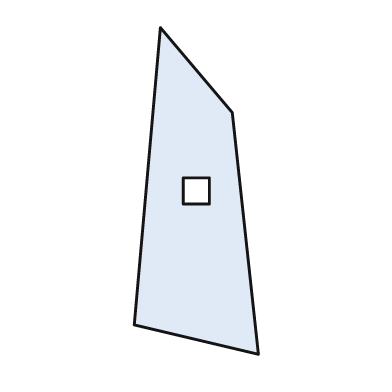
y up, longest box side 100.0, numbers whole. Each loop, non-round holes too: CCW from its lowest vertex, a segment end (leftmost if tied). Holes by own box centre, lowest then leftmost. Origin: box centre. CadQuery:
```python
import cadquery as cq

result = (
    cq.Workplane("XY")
    .moveTo(19.0, -50.0)
    .lineTo(11.0, 24.0)
    .lineTo(-11.0, 50.0)
    .lineTo(-19.0, -41.0)
    .close()
    .moveTo(-4.0, -4.0)
    .lineTo(4.0, -4.0)
    .lineTo(4.0, 4.0)
    .lineTo(-4.0, 4.0)
    .close()
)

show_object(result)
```